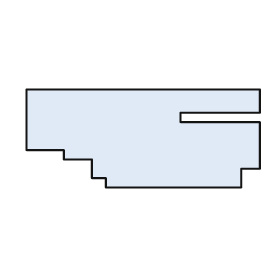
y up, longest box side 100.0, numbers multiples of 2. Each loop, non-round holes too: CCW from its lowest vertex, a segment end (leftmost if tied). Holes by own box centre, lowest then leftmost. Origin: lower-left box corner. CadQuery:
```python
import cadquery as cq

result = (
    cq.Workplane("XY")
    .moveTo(34.0, 0.0)
    .lineTo(92.0, 0.0)
    .lineTo(92.0, 8.0)
    .lineTo(100.0, 8.0)
    .lineTo(100.0, 28.0)
    .lineTo(66.0, 28.0)
    .lineTo(66.0, 32.0)
    .lineTo(100.0, 32.0)
    .lineTo(100.0, 42.0)
    .lineTo(0.0, 42.0)
    .lineTo(0.0, 16.0)
    .lineTo(16.0, 16.0)
    .lineTo(16.0, 12.0)
    .lineTo(28.0, 12.0)
    .lineTo(28.0, 4.0)
    .lineTo(34.0, 4.0)
    .close()
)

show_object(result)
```